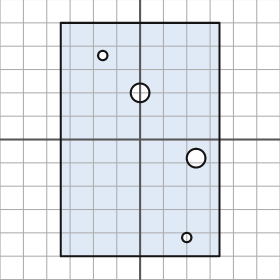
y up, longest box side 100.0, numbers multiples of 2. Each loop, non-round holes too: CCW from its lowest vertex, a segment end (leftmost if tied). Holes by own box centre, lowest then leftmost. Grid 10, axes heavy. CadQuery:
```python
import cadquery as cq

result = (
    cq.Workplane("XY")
    .moveTo(-34.0, -50.0)
    .lineTo(34.0, -50.0)
    .lineTo(34.0, 50.0)
    .lineTo(-34.0, 50.0)
    .close()
    .moveTo(20.0, -42.0)
    .circle(2.0)
    .moveTo(24.0, -8.0)
    .circle(4.0)
    .moveTo(0.0, 20.0)
    .circle(4.0)
    .moveTo(-16.0, 36.0)
    .circle(2.0)
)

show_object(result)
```